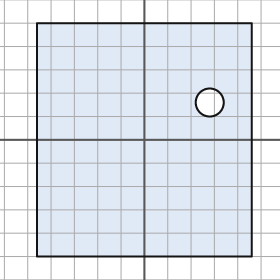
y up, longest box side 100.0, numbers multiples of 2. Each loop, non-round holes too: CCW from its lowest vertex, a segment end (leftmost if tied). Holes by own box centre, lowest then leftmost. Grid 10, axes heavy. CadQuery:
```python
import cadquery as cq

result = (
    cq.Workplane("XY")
    .moveTo(-46.0, -50.0)
    .lineTo(46.0, -50.0)
    .lineTo(46.0, 50.0)
    .lineTo(-46.0, 50.0)
    .close()
    .moveTo(28.0, 16.0)
    .circle(6.0)
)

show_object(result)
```